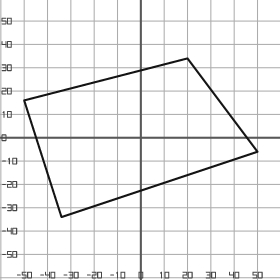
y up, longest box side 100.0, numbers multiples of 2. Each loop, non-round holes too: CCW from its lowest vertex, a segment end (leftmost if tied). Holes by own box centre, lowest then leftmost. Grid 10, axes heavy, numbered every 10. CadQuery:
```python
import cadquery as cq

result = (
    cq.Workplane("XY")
    .moveTo(-34.0, -34.0)
    .lineTo(50.0, -6.0)
    .lineTo(20.0, 34.0)
    .lineTo(-50.0, 16.0)
    .close()
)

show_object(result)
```